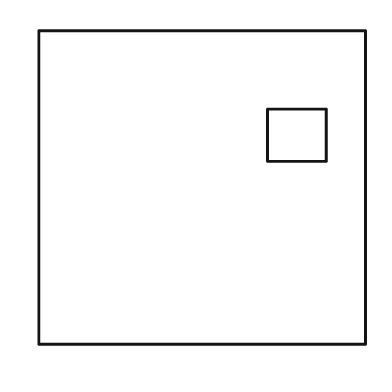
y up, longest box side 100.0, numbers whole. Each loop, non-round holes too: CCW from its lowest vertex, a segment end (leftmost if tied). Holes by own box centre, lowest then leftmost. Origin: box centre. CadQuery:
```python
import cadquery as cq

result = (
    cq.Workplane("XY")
    .moveTo(-50.0, -48.0)
    .lineTo(50.0, -48.0)
    .lineTo(50.0, 48.0)
    .lineTo(-50.0, 48.0)
    .close()
    .moveTo(20.0, 8.0)
    .lineTo(38.0, 8.0)
    .lineTo(38.0, 24.0)
    .lineTo(20.0, 24.0)
    .close()
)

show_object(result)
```